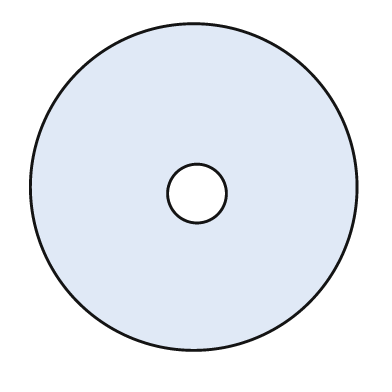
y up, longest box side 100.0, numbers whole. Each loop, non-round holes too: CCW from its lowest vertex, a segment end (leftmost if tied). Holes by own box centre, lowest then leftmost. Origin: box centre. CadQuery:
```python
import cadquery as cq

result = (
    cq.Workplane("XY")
    .moveTo(0.0, 0.0)
    .circle(50.0)
    .moveTo(1.0, -2.0)
    .circle(9.0)
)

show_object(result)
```